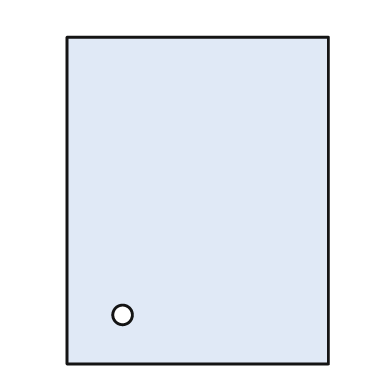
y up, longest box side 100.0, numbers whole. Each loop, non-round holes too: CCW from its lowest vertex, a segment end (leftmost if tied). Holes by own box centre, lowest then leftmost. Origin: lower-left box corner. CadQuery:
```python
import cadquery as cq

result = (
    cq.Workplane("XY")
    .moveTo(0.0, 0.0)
    .lineTo(80.0, 0.0)
    .lineTo(80.0, 100.0)
    .lineTo(0.0, 100.0)
    .close()
    .moveTo(17.0, 15.0)
    .circle(3.0)
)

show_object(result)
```